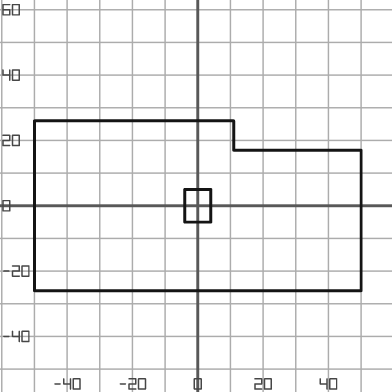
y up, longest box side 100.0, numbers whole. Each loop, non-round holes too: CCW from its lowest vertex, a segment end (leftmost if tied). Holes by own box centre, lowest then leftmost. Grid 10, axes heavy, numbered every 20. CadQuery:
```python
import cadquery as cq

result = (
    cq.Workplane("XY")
    .moveTo(-50.0, -26.0)
    .lineTo(50.0, -26.0)
    .lineTo(50.0, 17.0)
    .lineTo(11.0, 17.0)
    .lineTo(11.0, 26.0)
    .lineTo(-50.0, 26.0)
    .close()
    .moveTo(-4.0, -5.0)
    .lineTo(4.0, -5.0)
    .lineTo(4.0, 5.0)
    .lineTo(-4.0, 5.0)
    .close()
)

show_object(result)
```